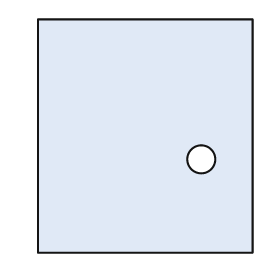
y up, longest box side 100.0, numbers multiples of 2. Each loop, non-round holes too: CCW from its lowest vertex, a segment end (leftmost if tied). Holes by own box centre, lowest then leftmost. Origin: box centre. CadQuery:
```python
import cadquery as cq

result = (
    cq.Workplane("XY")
    .moveTo(-46.0, -50.0)
    .lineTo(46.0, -50.0)
    .lineTo(46.0, 50.0)
    .lineTo(-46.0, 50.0)
    .close()
    .moveTo(24.0, -10.0)
    .circle(6.0)
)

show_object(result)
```